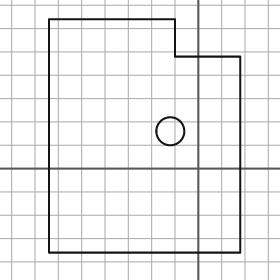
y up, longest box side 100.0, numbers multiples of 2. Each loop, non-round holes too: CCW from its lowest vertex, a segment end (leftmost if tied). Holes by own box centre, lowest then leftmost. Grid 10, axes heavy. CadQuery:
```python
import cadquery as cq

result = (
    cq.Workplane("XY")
    .moveTo(-64.0, -36.0)
    .lineTo(18.0, -36.0)
    .lineTo(18.0, 48.0)
    .lineTo(-10.0, 48.0)
    .lineTo(-10.0, 64.0)
    .lineTo(-64.0, 64.0)
    .close()
    .moveTo(-12.0, 16.0)
    .circle(6.0)
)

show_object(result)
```